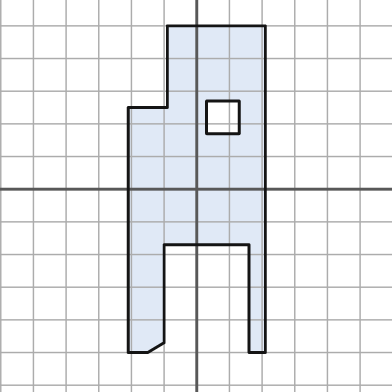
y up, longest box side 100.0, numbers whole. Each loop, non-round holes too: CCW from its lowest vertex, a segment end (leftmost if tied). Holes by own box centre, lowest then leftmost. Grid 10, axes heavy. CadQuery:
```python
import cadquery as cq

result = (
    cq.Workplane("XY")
    .moveTo(-21.0, -50.0)
    .lineTo(-15.0, -50.0)
    .lineTo(-10.0, -47.0)
    .lineTo(-10.0, -17.0)
    .lineTo(16.0, -17.0)
    .lineTo(16.0, -50.0)
    .lineTo(21.0, -50.0)
    .lineTo(21.0, 50.0)
    .lineTo(-9.0, 50.0)
    .lineTo(-9.0, 25.0)
    .lineTo(-21.0, 25.0)
    .close()
    .moveTo(3.0, 17.0)
    .lineTo(13.0, 17.0)
    .lineTo(13.0, 27.0)
    .lineTo(3.0, 27.0)
    .close()
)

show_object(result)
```